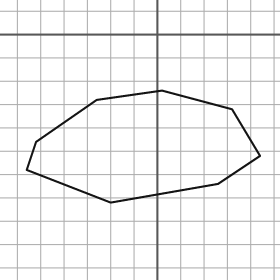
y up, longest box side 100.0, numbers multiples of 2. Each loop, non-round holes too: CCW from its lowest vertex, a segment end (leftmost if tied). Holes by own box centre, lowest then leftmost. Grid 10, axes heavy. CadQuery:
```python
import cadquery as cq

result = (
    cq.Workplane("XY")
    .moveTo(-20.0, -72.0)
    .lineTo(26.0, -64.0)
    .lineTo(44.0, -52.0)
    .lineTo(32.0, -32.0)
    .lineTo(2.0, -24.0)
    .lineTo(-26.0, -28.0)
    .lineTo(-52.0, -46.0)
    .lineTo(-56.0, -58.0)
    .close()
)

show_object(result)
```